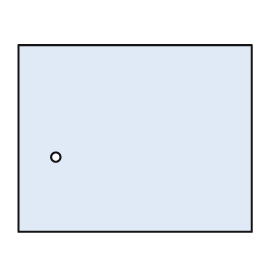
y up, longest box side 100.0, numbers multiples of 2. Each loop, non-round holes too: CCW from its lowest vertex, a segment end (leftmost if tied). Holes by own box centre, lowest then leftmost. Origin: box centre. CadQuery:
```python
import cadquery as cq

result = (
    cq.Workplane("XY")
    .moveTo(-50.0, -40.0)
    .lineTo(50.0, -40.0)
    .lineTo(50.0, 40.0)
    .lineTo(-50.0, 40.0)
    .close()
    .moveTo(-34.0, -8.0)
    .circle(2.0)
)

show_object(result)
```